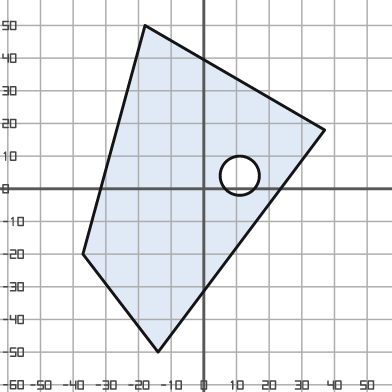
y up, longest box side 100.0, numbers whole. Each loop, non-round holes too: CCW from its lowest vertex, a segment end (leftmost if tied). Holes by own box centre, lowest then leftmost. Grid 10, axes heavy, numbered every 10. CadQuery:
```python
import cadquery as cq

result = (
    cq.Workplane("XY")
    .moveTo(-14.0, -50.0)
    .lineTo(37.0, 18.0)
    .lineTo(-18.0, 50.0)
    .lineTo(-37.0, -20.0)
    .close()
    .moveTo(11.0, 4.0)
    .circle(6.0)
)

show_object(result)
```